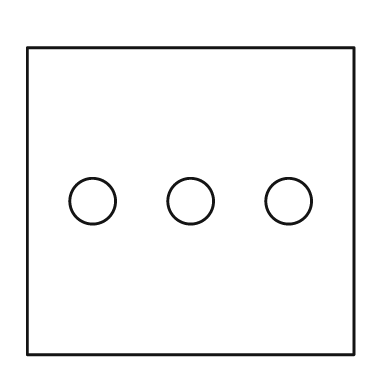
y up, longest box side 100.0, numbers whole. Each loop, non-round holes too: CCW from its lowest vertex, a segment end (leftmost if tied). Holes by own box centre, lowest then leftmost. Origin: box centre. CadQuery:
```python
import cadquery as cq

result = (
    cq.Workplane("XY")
    .moveTo(-50.0, -47.0)
    .lineTo(50.0, -47.0)
    .lineTo(50.0, 47.0)
    .lineTo(-50.0, 47.0)
    .close()
    .moveTo(-30.0, 0.0)
    .circle(7.0)
    .moveTo(0.0, 0.0)
    .circle(7.0)
    .moveTo(30.0, 0.0)
    .circle(7.0)
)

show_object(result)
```